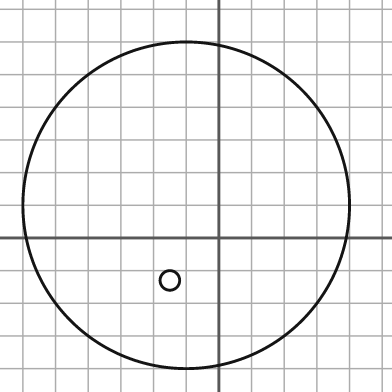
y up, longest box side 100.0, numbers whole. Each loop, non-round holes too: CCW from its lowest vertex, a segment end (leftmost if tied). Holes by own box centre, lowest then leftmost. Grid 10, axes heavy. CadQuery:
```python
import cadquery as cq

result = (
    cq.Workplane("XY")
    .moveTo(-10.0, 10.0)
    .circle(50.0)
    .moveTo(-15.0, -13.0)
    .circle(3.0)
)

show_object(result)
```